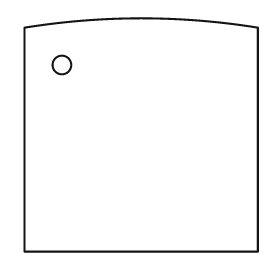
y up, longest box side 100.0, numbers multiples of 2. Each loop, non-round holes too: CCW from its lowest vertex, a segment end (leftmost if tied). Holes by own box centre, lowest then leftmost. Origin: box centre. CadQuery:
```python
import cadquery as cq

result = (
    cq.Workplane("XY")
    .moveTo(-50.0, -50.0)
    .lineTo(50.0, -50.0)
    .lineTo(50.0, 46.0)
    .threePointArc((0.0, 50.0), (-50.0, 46.0))
    .close()
    .moveTo(-34.0, 30.0)
    .circle(4.0)
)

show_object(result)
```